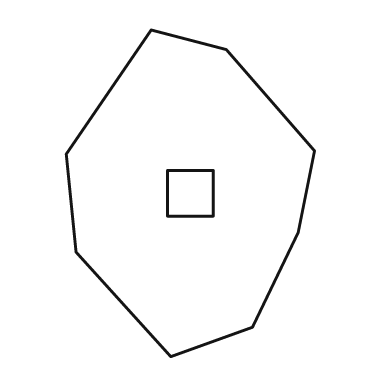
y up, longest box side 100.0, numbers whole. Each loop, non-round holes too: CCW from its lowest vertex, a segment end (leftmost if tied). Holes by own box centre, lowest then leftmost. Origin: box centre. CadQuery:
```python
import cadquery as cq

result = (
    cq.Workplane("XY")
    .moveTo(-6.0, -50.0)
    .lineTo(19.0, -41.0)
    .lineTo(33.0, -12.0)
    .lineTo(38.0, 13.0)
    .lineTo(11.0, 44.0)
    .lineTo(-12.0, 50.0)
    .lineTo(-38.0, 12.0)
    .lineTo(-35.0, -18.0)
    .close()
    .moveTo(-7.0, -7.0)
    .lineTo(7.0, -7.0)
    .lineTo(7.0, 7.0)
    .lineTo(-7.0, 7.0)
    .close()
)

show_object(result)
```